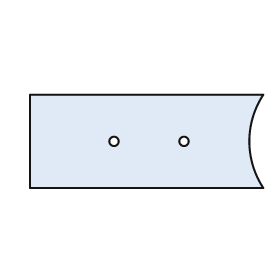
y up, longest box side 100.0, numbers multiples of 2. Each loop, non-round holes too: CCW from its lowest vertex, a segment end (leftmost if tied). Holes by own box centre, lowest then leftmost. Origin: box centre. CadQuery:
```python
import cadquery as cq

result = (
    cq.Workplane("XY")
    .moveTo(-50.0, -20.0)
    .lineTo(50.0, -20.0)
    .threePointArc((44.0, 0.0), (50.0, 20.0))
    .lineTo(-50.0, 20.0)
    .close()
    .moveTo(-14.0, 0.0)
    .circle(2.0)
    .moveTo(16.0, 0.0)
    .circle(2.0)
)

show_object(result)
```